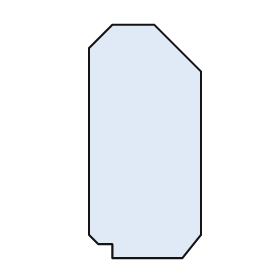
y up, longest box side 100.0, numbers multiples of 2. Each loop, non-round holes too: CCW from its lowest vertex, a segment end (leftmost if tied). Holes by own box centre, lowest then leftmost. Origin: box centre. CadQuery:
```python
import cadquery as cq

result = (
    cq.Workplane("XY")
    .moveTo(-14.0, -50.0)
    .lineTo(16.0, -50.0)
    .lineTo(24.0, -40.0)
    .lineTo(24.0, 30.0)
    .lineTo(4.0, 50.0)
    .lineTo(-14.0, 50.0)
    .lineTo(-24.0, 40.0)
    .lineTo(-24.0, -40.0)
    .lineTo(-20.0, -44.0)
    .lineTo(-14.0, -44.0)
    .close()
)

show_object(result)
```